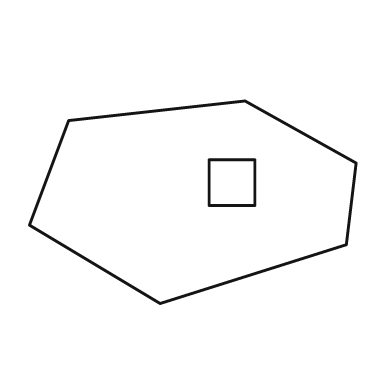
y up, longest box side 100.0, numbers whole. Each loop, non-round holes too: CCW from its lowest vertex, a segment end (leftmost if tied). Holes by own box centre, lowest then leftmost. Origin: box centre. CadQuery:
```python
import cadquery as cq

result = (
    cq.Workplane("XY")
    .moveTo(-10.0, -31.0)
    .lineTo(47.0, -13.0)
    .lineTo(50.0, 12.0)
    .lineTo(16.0, 31.0)
    .lineTo(-38.0, 25.0)
    .lineTo(-50.0, -7.0)
    .close()
    .moveTo(5.0, -1.0)
    .lineTo(19.0, -1.0)
    .lineTo(19.0, 13.0)
    .lineTo(5.0, 13.0)
    .close()
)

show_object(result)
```